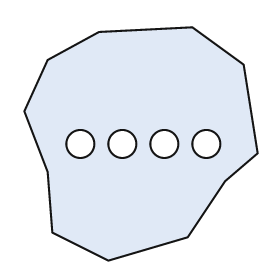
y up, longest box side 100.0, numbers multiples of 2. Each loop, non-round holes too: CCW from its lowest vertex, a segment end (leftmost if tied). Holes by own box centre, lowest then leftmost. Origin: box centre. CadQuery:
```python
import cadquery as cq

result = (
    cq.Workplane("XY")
    .moveTo(-14.0, -50.0)
    .lineTo(20.0, -40.0)
    .lineTo(36.0, -16.0)
    .lineTo(50.0, -4.0)
    .lineTo(44.0, 34.0)
    .lineTo(22.0, 50.0)
    .lineTo(-18.0, 48.0)
    .lineTo(-40.0, 36.0)
    .lineTo(-50.0, 14.0)
    .lineTo(-40.0, -12.0)
    .lineTo(-38.0, -38.0)
    .close()
    .moveTo(-26.0, 0.0)
    .circle(6.0)
    .moveTo(-8.0, 0.0)
    .circle(6.0)
    .moveTo(10.0, 0.0)
    .circle(6.0)
    .moveTo(28.0, 0.0)
    .circle(6.0)
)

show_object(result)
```